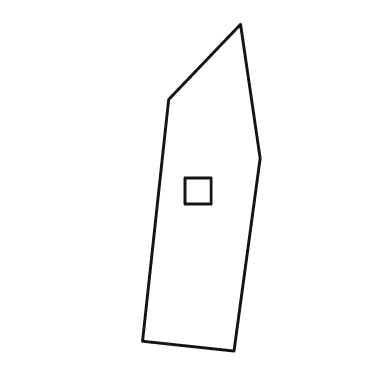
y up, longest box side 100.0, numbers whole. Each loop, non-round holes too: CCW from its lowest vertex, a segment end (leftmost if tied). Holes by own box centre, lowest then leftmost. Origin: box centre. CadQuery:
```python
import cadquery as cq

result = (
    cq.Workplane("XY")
    .moveTo(10.0, -50.0)
    .lineTo(18.0, 9.0)
    .lineTo(12.0, 50.0)
    .lineTo(-10.0, 27.0)
    .lineTo(-18.0, -47.0)
    .close()
    .moveTo(-5.0, -5.0)
    .lineTo(3.0, -5.0)
    .lineTo(3.0, 3.0)
    .lineTo(-5.0, 3.0)
    .close()
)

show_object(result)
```